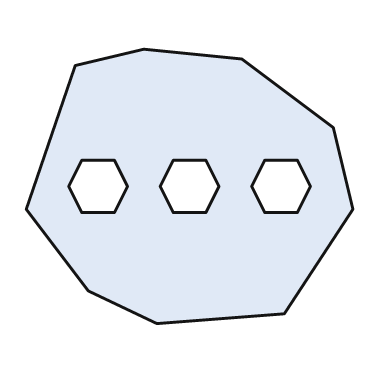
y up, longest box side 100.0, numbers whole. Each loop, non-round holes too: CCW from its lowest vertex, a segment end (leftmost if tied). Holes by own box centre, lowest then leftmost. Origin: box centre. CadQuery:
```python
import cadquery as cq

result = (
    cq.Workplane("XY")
    .moveTo(-10.0, -42.0)
    .lineTo(29.0, -39.0)
    .lineTo(50.0, -7.0)
    .lineTo(44.0, 18.0)
    .lineTo(16.0, 39.0)
    .lineTo(-14.0, 42.0)
    .lineTo(-35.0, 37.0)
    .lineTo(-50.0, -7.0)
    .lineTo(-31.0, -32.0)
    .close()
    .moveTo(-33.0, -8.0)
    .lineTo(-23.0, -8.0)
    .lineTo(-19.0, 0.0)
    .lineTo(-23.0, 8.0)
    .lineTo(-33.0, 8.0)
    .lineTo(-37.0, 0.0)
    .close()
    .moveTo(-5.0, -8.0)
    .lineTo(5.0, -8.0)
    .lineTo(9.0, 0.0)
    .lineTo(5.0, 8.0)
    .lineTo(-5.0, 8.0)
    .lineTo(-9.0, 0.0)
    .close()
    .moveTo(23.0, -8.0)
    .lineTo(33.0, -8.0)
    .lineTo(37.0, 0.0)
    .lineTo(33.0, 8.0)
    .lineTo(23.0, 8.0)
    .lineTo(19.0, 0.0)
    .close()
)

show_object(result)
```